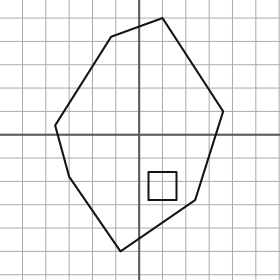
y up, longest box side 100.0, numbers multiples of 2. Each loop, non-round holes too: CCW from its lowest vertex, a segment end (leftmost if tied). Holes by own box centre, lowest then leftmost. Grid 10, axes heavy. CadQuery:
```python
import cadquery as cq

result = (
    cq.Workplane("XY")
    .moveTo(-8.0, -50.0)
    .lineTo(24.0, -28.0)
    .lineTo(36.0, 10.0)
    .lineTo(10.0, 50.0)
    .lineTo(-12.0, 42.0)
    .lineTo(-36.0, 4.0)
    .lineTo(-30.0, -18.0)
    .close()
    .moveTo(4.0, -28.0)
    .lineTo(16.0, -28.0)
    .lineTo(16.0, -16.0)
    .lineTo(4.0, -16.0)
    .close()
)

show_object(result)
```